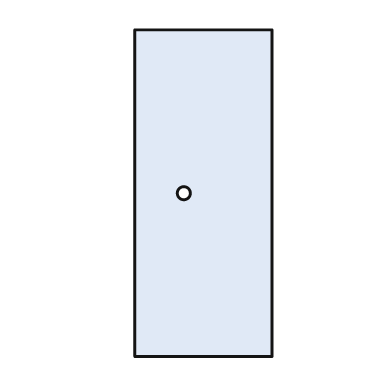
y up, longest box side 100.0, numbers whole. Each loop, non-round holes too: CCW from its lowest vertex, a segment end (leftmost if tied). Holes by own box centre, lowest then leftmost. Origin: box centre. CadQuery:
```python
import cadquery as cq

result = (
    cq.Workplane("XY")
    .moveTo(-21.0, -50.0)
    .lineTo(21.0, -50.0)
    .lineTo(21.0, 50.0)
    .lineTo(-21.0, 50.0)
    .close()
    .moveTo(-6.0, 0.0)
    .circle(2.0)
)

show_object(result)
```